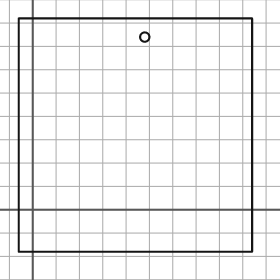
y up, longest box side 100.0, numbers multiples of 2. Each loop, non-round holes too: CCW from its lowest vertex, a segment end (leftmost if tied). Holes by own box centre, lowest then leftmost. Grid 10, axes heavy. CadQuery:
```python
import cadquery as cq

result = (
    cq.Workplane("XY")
    .moveTo(-6.0, -18.0)
    .lineTo(94.0, -18.0)
    .lineTo(94.0, 82.0)
    .lineTo(-6.0, 82.0)
    .close()
    .moveTo(48.0, 74.0)
    .circle(2.0)
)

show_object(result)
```